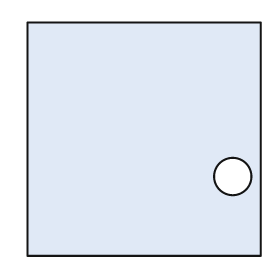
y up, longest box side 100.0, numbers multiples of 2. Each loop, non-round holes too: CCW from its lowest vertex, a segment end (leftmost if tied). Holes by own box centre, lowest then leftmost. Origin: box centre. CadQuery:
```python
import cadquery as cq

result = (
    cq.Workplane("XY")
    .moveTo(-50.0, -50.0)
    .lineTo(50.0, -50.0)
    .lineTo(50.0, 50.0)
    .lineTo(-50.0, 50.0)
    .close()
    .moveTo(38.0, -16.0)
    .circle(8.0)
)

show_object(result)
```